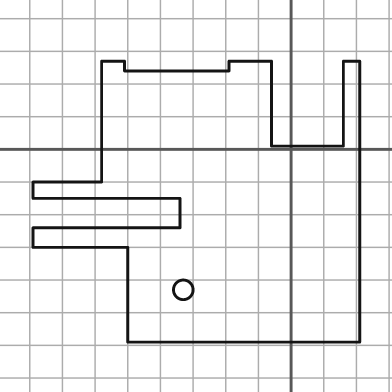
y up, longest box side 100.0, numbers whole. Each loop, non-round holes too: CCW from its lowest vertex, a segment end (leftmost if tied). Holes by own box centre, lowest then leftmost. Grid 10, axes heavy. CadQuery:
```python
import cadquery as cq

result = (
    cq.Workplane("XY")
    .moveTo(-50.0, -59.0)
    .lineTo(21.0, -59.0)
    .lineTo(21.0, 27.0)
    .lineTo(16.0, 27.0)
    .lineTo(16.0, 1.0)
    .lineTo(-6.0, 1.0)
    .lineTo(-6.0, 27.0)
    .lineTo(-19.0, 27.0)
    .lineTo(-19.0, 24.0)
    .lineTo(-51.0, 24.0)
    .lineTo(-51.0, 27.0)
    .lineTo(-58.0, 27.0)
    .lineTo(-58.0, -10.0)
    .lineTo(-79.0, -10.0)
    .lineTo(-79.0, -15.0)
    .lineTo(-34.0, -15.0)
    .lineTo(-34.0, -24.0)
    .lineTo(-79.0, -24.0)
    .lineTo(-79.0, -30.0)
    .lineTo(-50.0, -30.0)
    .close()
    .moveTo(-33.0, -43.0)
    .circle(3.0)
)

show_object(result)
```